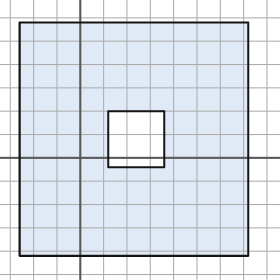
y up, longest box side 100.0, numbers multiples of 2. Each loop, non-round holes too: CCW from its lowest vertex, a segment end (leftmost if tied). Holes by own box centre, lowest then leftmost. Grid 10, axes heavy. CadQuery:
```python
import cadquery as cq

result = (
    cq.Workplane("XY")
    .moveTo(-26.0, -42.0)
    .lineTo(72.0, -42.0)
    .lineTo(72.0, 58.0)
    .lineTo(-26.0, 58.0)
    .close()
    .moveTo(12.0, -4.0)
    .lineTo(36.0, -4.0)
    .lineTo(36.0, 20.0)
    .lineTo(12.0, 20.0)
    .close()
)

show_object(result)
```